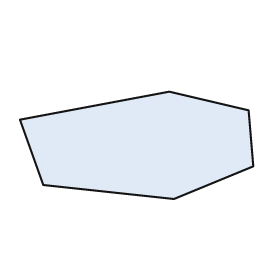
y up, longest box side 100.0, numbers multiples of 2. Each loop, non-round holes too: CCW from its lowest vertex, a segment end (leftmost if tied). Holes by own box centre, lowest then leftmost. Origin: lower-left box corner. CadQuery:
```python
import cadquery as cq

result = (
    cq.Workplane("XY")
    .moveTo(66.0, 0.0)
    .lineTo(100.0, 14.0)
    .lineTo(98.0, 38.0)
    .lineTo(64.0, 46.0)
    .lineTo(0.0, 34.0)
    .lineTo(10.0, 6.0)
    .close()
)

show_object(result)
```